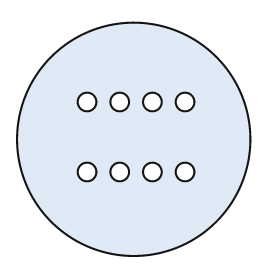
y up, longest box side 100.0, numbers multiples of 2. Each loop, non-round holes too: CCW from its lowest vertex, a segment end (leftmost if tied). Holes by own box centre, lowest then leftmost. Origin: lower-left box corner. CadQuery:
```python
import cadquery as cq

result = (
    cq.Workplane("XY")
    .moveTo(50.0, 50.0)
    .circle(50.0)
    .moveTo(30.0, 36.0)
    .circle(4.0)
    .moveTo(44.0, 36.0)
    .circle(4.0)
    .moveTo(58.0, 36.0)
    .circle(4.0)
    .moveTo(72.0, 36.0)
    .circle(4.0)
    .moveTo(30.0, 66.0)
    .circle(4.0)
    .moveTo(44.0, 66.0)
    .circle(4.0)
    .moveTo(58.0, 66.0)
    .circle(4.0)
    .moveTo(72.0, 66.0)
    .circle(4.0)
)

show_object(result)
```